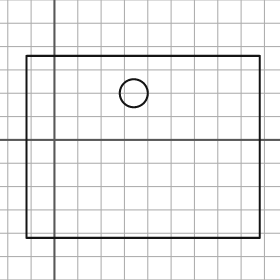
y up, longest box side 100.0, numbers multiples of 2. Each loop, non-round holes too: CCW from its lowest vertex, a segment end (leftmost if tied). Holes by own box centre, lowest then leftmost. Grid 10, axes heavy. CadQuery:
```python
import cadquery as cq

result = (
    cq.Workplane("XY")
    .moveTo(-12.0, -42.0)
    .lineTo(88.0, -42.0)
    .lineTo(88.0, 36.0)
    .lineTo(-12.0, 36.0)
    .close()
    .moveTo(34.0, 20.0)
    .circle(6.0)
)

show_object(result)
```